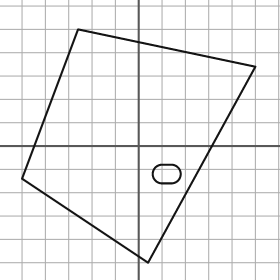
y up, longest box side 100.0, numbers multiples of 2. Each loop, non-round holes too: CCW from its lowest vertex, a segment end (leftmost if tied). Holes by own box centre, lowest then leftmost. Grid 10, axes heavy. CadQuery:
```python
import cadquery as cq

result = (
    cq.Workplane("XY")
    .moveTo(4.0, -50.0)
    .lineTo(50.0, 34.0)
    .lineTo(-26.0, 50.0)
    .lineTo(-50.0, -14.0)
    .close()
    .moveTo(10.0, -16.0)
    .lineTo(14.0, -16.0)
    .threePointArc((18.0, -12.0), (14.0, -8.0))
    .lineTo(10.0, -8.0)
    .threePointArc((6.0, -12.0), (10.0, -16.0))
    .close()
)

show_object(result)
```